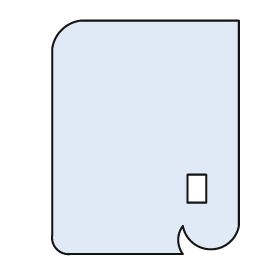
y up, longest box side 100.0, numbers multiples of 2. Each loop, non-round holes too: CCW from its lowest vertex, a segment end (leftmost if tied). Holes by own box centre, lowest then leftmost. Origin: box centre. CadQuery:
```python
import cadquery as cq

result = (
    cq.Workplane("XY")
    .moveTo(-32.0, -50.0)
    .lineTo(16.0, -50.0)
    .threePointArc((14.0, -44.0), (16.0, -38.0))
    .threePointArc((28.0, -48.0), (40.0, -38.0))
    .lineTo(40.0, 50.0)
    .lineTo(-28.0, 50.0)
    .threePointArc((-36.0, 46.0), (-40.0, 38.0))
    .lineTo(-40.0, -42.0)
    .threePointArc((-38.0, -48.0), (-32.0, -50.0))
    .close()
    .moveTo(18.0, -28.0)
    .lineTo(26.0, -28.0)
    .lineTo(26.0, -16.0)
    .lineTo(18.0, -16.0)
    .close()
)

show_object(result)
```